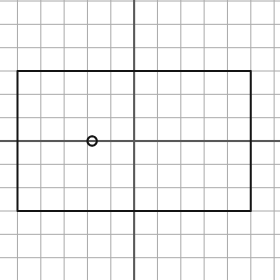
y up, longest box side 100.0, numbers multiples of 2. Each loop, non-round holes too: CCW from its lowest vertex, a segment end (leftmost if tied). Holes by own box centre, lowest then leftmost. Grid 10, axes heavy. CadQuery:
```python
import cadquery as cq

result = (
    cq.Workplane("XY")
    .moveTo(-50.0, -30.0)
    .lineTo(50.0, -30.0)
    .lineTo(50.0, 30.0)
    .lineTo(-50.0, 30.0)
    .close()
    .moveTo(-18.0, 0.0)
    .circle(2.0)
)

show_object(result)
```